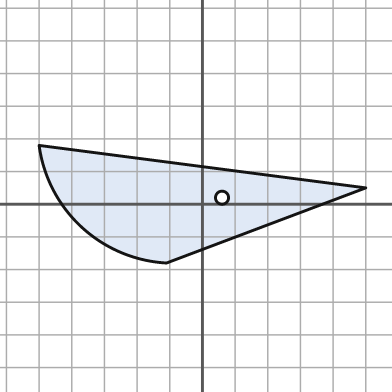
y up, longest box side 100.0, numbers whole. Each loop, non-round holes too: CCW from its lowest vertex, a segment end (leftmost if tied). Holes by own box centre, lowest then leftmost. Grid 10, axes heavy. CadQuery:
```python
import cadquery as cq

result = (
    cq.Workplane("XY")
    .moveTo(-11.0, -18.0)
    .lineTo(50.0, 5.0)
    .lineTo(-50.0, 18.0)
    .threePointArc((-37.0, -7.0), (-11.0, -18.0))
    .close()
    .moveTo(6.0, 2.0)
    .circle(2.0)
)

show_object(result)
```